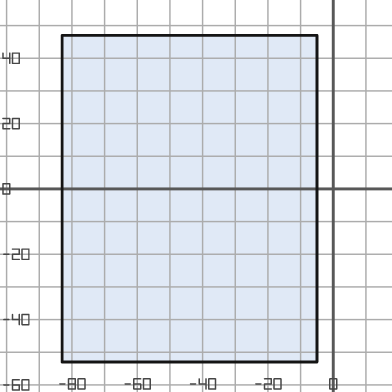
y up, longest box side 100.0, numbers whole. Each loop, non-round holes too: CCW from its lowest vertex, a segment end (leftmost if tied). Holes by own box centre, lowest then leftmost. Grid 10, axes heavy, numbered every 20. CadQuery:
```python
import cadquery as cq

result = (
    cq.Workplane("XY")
    .moveTo(-83.0, -53.0)
    .lineTo(-5.0, -53.0)
    .lineTo(-5.0, 47.0)
    .lineTo(-83.0, 47.0)
    .close()
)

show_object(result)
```